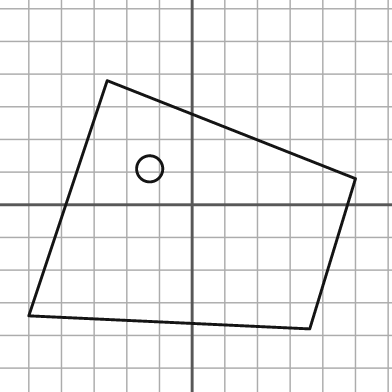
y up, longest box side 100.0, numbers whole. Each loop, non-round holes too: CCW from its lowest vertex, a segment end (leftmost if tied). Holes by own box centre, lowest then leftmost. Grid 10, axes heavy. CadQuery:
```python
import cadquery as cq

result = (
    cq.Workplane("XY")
    .moveTo(36.0, -38.0)
    .lineTo(50.0, 8.0)
    .lineTo(-26.0, 38.0)
    .lineTo(-50.0, -34.0)
    .close()
    .moveTo(-13.0, 11.0)
    .circle(4.0)
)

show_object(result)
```